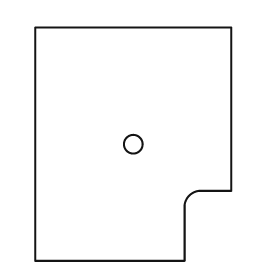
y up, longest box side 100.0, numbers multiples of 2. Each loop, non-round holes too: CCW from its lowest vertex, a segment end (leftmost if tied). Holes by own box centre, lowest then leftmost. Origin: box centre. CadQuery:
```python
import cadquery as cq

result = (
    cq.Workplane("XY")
    .moveTo(-42.0, -50.0)
    .lineTo(22.0, -50.0)
    .lineTo(22.0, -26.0)
    .threePointArc((24.0, -22.0), (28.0, -20.0))
    .lineTo(42.0, -20.0)
    .lineTo(42.0, 50.0)
    .lineTo(-42.0, 50.0)
    .close()
    .moveTo(0.0, 0.0)
    .circle(4.0)
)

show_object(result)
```